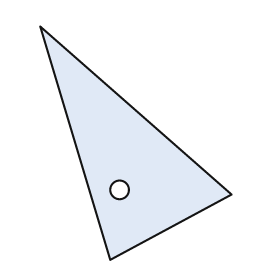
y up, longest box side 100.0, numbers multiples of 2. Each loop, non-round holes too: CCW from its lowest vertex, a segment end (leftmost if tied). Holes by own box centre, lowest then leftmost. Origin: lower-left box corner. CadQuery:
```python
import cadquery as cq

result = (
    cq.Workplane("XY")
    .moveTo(30.0, 0.0)
    .lineTo(82.0, 28.0)
    .lineTo(0.0, 100.0)
    .close()
    .moveTo(34.0, 30.0)
    .circle(4.0)
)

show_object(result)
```